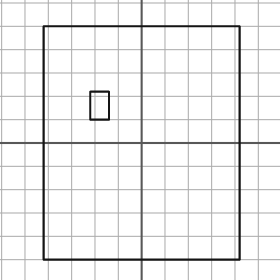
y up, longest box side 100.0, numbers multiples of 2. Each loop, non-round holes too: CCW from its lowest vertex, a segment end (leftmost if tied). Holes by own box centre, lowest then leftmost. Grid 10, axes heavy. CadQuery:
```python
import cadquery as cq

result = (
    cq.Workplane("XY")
    .moveTo(-42.0, -50.0)
    .lineTo(42.0, -50.0)
    .lineTo(42.0, 50.0)
    .lineTo(-42.0, 50.0)
    .close()
    .moveTo(-22.0, 10.0)
    .lineTo(-14.0, 10.0)
    .lineTo(-14.0, 22.0)
    .lineTo(-22.0, 22.0)
    .close()
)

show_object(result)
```